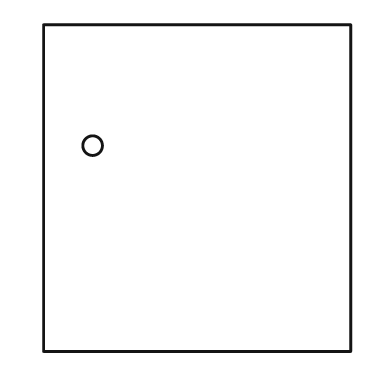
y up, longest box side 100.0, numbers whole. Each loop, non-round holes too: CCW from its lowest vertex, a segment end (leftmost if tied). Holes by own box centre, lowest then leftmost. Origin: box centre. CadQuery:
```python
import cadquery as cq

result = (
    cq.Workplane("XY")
    .moveTo(-47.0, -50.0)
    .lineTo(47.0, -50.0)
    .lineTo(47.0, 50.0)
    .lineTo(-47.0, 50.0)
    .close()
    .moveTo(-32.0, 13.0)
    .circle(3.0)
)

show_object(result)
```